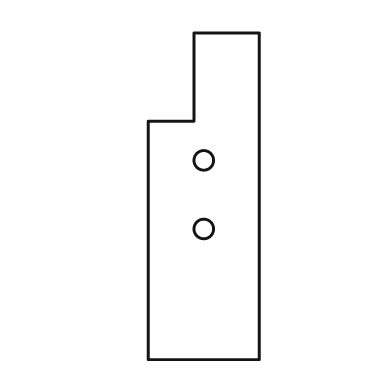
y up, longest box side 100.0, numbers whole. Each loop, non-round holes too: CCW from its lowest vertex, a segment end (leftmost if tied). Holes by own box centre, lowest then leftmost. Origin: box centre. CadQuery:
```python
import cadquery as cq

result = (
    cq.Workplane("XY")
    .moveTo(-17.0, -50.0)
    .lineTo(17.0, -50.0)
    .lineTo(17.0, 50.0)
    .lineTo(-3.0, 50.0)
    .lineTo(-3.0, 23.0)
    .lineTo(-17.0, 23.0)
    .close()
    .moveTo(0.0, -10.0)
    .circle(3.0)
    .moveTo(0.0, 11.0)
    .circle(3.0)
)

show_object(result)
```